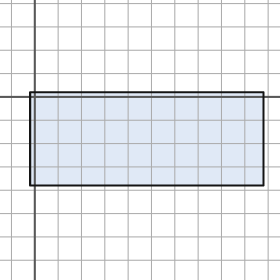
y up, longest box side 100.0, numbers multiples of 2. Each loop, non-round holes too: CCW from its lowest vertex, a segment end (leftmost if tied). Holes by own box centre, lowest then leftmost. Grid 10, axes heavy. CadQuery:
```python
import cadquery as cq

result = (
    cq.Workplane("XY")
    .moveTo(-2.0, -38.0)
    .lineTo(98.0, -38.0)
    .lineTo(98.0, 2.0)
    .lineTo(-2.0, 2.0)
    .close()
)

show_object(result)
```